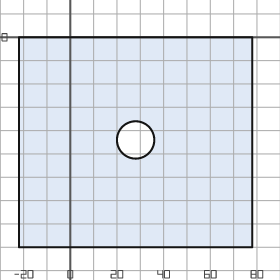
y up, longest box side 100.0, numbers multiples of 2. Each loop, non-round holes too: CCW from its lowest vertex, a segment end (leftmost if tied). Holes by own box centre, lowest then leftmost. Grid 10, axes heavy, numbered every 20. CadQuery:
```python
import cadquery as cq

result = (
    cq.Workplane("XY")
    .moveTo(-22.0, -90.0)
    .lineTo(78.0, -90.0)
    .lineTo(78.0, 0.0)
    .lineTo(-22.0, 0.0)
    .close()
    .moveTo(28.0, -44.0)
    .circle(8.0)
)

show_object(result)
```